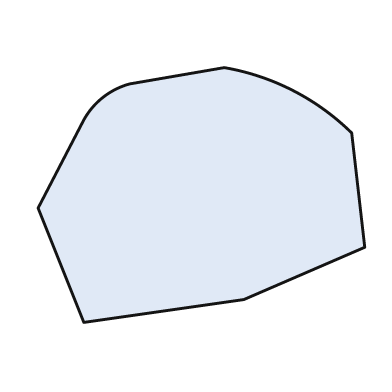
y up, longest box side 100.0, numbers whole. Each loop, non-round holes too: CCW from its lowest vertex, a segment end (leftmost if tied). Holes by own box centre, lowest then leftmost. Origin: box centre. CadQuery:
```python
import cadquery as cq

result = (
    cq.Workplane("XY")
    .moveTo(-36.0, -39.0)
    .lineTo(13.0, -32.0)
    .lineTo(50.0, -16.0)
    .lineTo(46.0, 19.0)
    .threePointArc((28.0, 32.0), (7.0, 39.0))
    .lineTo(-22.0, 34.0)
    .threePointArc((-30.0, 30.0), (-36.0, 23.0))
    .lineTo(-50.0, -4.0)
    .close()
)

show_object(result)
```